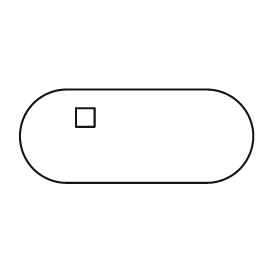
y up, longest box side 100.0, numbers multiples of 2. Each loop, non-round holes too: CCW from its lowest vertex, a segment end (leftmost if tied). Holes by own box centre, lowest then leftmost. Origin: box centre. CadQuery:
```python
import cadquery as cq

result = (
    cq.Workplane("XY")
    .moveTo(-30.0, -20.0)
    .lineTo(30.0, -20.0)
    .threePointArc((50.0, 0.0), (30.0, 20.0))
    .lineTo(-30.0, 20.0)
    .threePointArc((-50.0, 0.0), (-30.0, -20.0))
    .close()
    .moveTo(-26.0, 4.0)
    .lineTo(-18.0, 4.0)
    .lineTo(-18.0, 12.0)
    .lineTo(-26.0, 12.0)
    .close()
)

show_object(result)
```